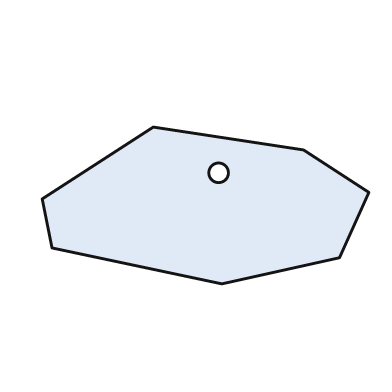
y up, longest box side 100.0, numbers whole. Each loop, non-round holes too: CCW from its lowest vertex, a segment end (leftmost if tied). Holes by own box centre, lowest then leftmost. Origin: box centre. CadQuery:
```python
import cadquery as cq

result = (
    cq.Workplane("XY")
    .moveTo(5.0, -24.0)
    .lineTo(41.0, -16.0)
    .lineTo(50.0, 4.0)
    .lineTo(30.0, 17.0)
    .lineTo(-16.0, 24.0)
    .lineTo(-50.0, 2.0)
    .lineTo(-47.0, -13.0)
    .close()
    .moveTo(4.0, 10.0)
    .circle(3.0)
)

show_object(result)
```